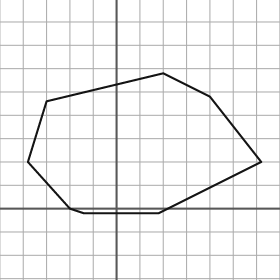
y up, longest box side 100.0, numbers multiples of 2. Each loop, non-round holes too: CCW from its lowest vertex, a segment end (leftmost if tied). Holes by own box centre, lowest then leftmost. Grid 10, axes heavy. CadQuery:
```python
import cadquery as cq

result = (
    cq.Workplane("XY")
    .moveTo(-14.0, -2.0)
    .lineTo(18.0, -2.0)
    .lineTo(62.0, 20.0)
    .lineTo(40.0, 48.0)
    .lineTo(20.0, 58.0)
    .lineTo(-30.0, 46.0)
    .lineTo(-38.0, 20.0)
    .lineTo(-20.0, 0.0)
    .close()
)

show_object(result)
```